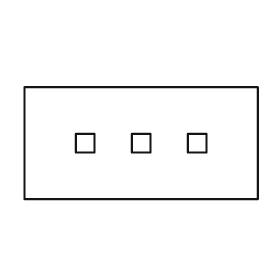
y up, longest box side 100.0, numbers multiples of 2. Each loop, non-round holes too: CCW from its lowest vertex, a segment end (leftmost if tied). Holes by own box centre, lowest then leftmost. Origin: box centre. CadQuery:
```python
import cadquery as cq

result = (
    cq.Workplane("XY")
    .moveTo(-50.0, -24.0)
    .lineTo(50.0, -24.0)
    .lineTo(50.0, 24.0)
    .lineTo(-50.0, 24.0)
    .close()
    .moveTo(-28.0, -4.0)
    .lineTo(-20.0, -4.0)
    .lineTo(-20.0, 4.0)
    .lineTo(-28.0, 4.0)
    .close()
    .moveTo(-4.0, -4.0)
    .lineTo(4.0, -4.0)
    .lineTo(4.0, 4.0)
    .lineTo(-4.0, 4.0)
    .close()
    .moveTo(20.0, -4.0)
    .lineTo(28.0, -4.0)
    .lineTo(28.0, 4.0)
    .lineTo(20.0, 4.0)
    .close()
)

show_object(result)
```